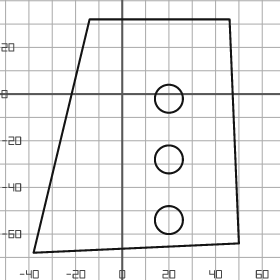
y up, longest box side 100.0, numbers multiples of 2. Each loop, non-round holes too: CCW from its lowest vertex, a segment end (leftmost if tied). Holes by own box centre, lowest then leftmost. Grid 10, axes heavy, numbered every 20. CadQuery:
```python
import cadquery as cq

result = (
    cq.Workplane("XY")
    .moveTo(-38.0, -68.0)
    .lineTo(50.0, -64.0)
    .lineTo(46.0, 32.0)
    .lineTo(-14.0, 32.0)
    .close()
    .moveTo(20.0, -54.0)
    .circle(6.0)
    .moveTo(20.0, -28.0)
    .circle(6.0)
    .moveTo(20.0, -2.0)
    .circle(6.0)
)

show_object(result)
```